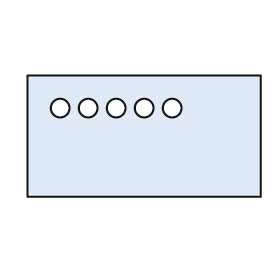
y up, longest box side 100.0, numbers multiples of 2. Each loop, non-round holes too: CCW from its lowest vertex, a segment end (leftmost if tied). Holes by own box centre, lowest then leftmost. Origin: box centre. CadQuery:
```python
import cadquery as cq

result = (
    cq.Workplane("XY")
    .moveTo(-50.0, -26.0)
    .lineTo(50.0, -26.0)
    .lineTo(50.0, 26.0)
    .lineTo(-50.0, 26.0)
    .close()
    .moveTo(-36.0, 12.0)
    .circle(4.0)
    .moveTo(-24.0, 12.0)
    .circle(4.0)
    .moveTo(-12.0, 12.0)
    .circle(4.0)
    .moveTo(0.0, 12.0)
    .circle(4.0)
    .moveTo(12.0, 12.0)
    .circle(4.0)
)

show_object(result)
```